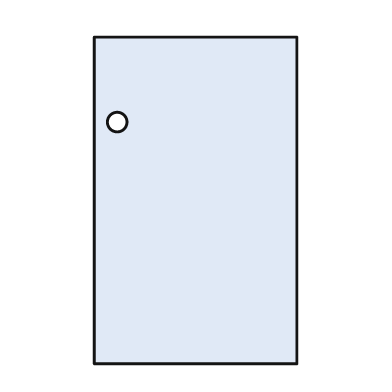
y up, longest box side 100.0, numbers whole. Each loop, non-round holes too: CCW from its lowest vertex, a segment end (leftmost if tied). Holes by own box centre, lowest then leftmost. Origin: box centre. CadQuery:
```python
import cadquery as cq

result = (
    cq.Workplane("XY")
    .moveTo(-31.0, -50.0)
    .lineTo(31.0, -50.0)
    .lineTo(31.0, 50.0)
    .lineTo(-31.0, 50.0)
    .close()
    .moveTo(-24.0, 24.0)
    .circle(3.0)
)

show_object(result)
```